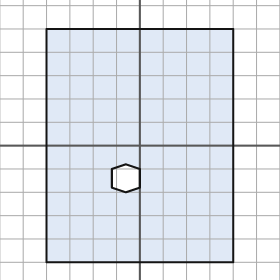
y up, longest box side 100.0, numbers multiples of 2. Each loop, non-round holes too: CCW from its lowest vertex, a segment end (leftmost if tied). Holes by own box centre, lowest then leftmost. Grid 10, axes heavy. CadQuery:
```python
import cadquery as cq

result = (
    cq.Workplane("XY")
    .moveTo(-40.0, -50.0)
    .lineTo(40.0, -50.0)
    .lineTo(40.0, 50.0)
    .lineTo(-40.0, 50.0)
    .close()
    .moveTo(-6.0, -20.0)
    .lineTo(0.0, -18.0)
    .lineTo(0.0, -10.0)
    .lineTo(-6.0, -8.0)
    .lineTo(-12.0, -10.0)
    .lineTo(-12.0, -18.0)
    .close()
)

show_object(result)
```